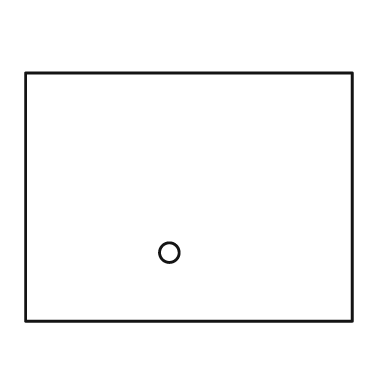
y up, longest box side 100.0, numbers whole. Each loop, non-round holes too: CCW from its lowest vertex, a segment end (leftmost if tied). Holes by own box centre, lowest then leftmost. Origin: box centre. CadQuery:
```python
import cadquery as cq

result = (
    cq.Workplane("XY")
    .moveTo(-50.0, -38.0)
    .lineTo(50.0, -38.0)
    .lineTo(50.0, 38.0)
    .lineTo(-50.0, 38.0)
    .close()
    .moveTo(-6.0, -17.0)
    .circle(3.0)
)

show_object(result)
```